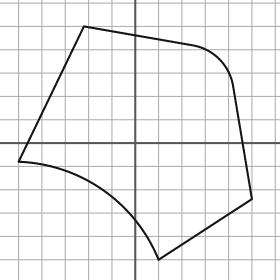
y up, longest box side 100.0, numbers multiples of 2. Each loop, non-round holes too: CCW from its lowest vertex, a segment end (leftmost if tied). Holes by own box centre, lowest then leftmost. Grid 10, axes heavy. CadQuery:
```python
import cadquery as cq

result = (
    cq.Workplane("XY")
    .moveTo(10.0, -50.0)
    .lineTo(50.0, -24.0)
    .lineTo(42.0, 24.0)
    .threePointArc((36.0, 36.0), (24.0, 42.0))
    .lineTo(-22.0, 50.0)
    .lineTo(-50.0, -8.0)
    .threePointArc((-14.0, -20.0), (10.0, -50.0))
    .close()
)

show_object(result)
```